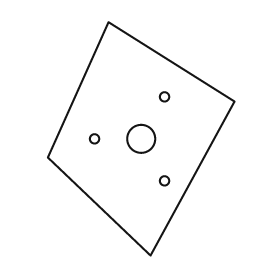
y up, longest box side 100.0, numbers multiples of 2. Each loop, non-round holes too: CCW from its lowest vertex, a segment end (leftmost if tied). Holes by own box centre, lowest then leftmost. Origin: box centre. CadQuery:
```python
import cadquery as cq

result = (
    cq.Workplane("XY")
    .moveTo(4.0, -50.0)
    .lineTo(40.0, 16.0)
    .lineTo(-14.0, 50.0)
    .lineTo(-40.0, -8.0)
    .close()
    .moveTo(10.0, -18.0)
    .circle(2.0)
    .moveTo(-20.0, 0.0)
    .circle(2.0)
    .moveTo(0.0, 0.0)
    .circle(6.0)
    .moveTo(10.0, 18.0)
    .circle(2.0)
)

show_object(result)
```